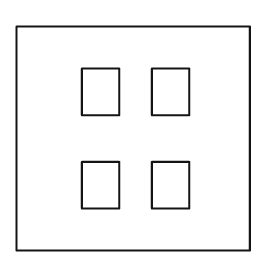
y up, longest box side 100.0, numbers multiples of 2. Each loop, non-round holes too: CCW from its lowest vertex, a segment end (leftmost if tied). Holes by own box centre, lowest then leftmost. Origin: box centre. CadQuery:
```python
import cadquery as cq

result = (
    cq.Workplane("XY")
    .moveTo(-50.0, -48.0)
    .lineTo(50.0, -48.0)
    .lineTo(50.0, 48.0)
    .lineTo(-50.0, 48.0)
    .close()
    .moveTo(-22.0, -30.0)
    .lineTo(-6.0, -30.0)
    .lineTo(-6.0, -10.0)
    .lineTo(-22.0, -10.0)
    .close()
    .moveTo(8.0, -30.0)
    .lineTo(24.0, -30.0)
    .lineTo(24.0, -10.0)
    .lineTo(8.0, -10.0)
    .close()
    .moveTo(-22.0, 10.0)
    .lineTo(-6.0, 10.0)
    .lineTo(-6.0, 30.0)
    .lineTo(-22.0, 30.0)
    .close()
    .moveTo(8.0, 10.0)
    .lineTo(24.0, 10.0)
    .lineTo(24.0, 30.0)
    .lineTo(8.0, 30.0)
    .close()
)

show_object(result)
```